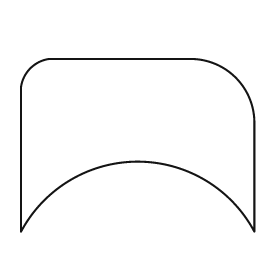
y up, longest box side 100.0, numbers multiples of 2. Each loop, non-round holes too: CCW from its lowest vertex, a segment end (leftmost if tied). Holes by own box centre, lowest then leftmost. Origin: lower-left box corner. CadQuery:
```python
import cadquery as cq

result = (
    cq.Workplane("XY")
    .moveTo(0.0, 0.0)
    .threePointArc((50.0, 30.0), (100.0, 0.0))
    .lineTo(100.0, 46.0)
    .threePointArc((92.0, 66.0), (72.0, 74.0))
    .lineTo(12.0, 74.0)
    .threePointArc((4.0, 70.0), (0.0, 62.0))
    .close()
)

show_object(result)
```